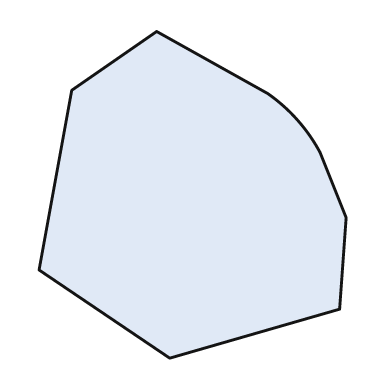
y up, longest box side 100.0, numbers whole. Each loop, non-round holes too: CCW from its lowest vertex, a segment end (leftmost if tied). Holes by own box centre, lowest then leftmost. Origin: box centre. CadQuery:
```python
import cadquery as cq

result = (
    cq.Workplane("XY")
    .moveTo(-7.0, -50.0)
    .lineTo(45.0, -35.0)
    .lineTo(47.0, -7.0)
    .lineTo(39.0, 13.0)
    .threePointArc((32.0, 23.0), (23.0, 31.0))
    .lineTo(-11.0, 50.0)
    .lineTo(-37.0, 32.0)
    .lineTo(-47.0, -23.0)
    .close()
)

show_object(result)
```